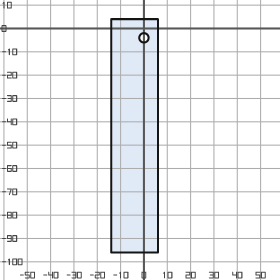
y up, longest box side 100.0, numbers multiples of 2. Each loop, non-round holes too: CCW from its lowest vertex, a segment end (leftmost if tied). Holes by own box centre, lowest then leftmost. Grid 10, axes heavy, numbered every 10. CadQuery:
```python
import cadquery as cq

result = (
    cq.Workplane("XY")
    .moveTo(-14.0, -96.0)
    .lineTo(6.0, -96.0)
    .lineTo(6.0, 4.0)
    .lineTo(-14.0, 4.0)
    .close()
    .moveTo(0.0, -4.0)
    .circle(2.0)
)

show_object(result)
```